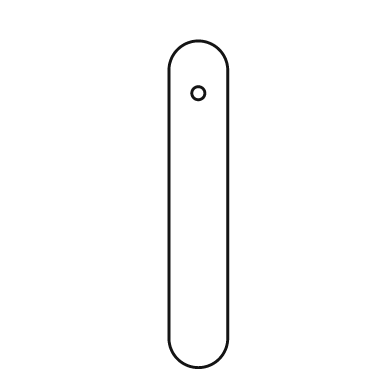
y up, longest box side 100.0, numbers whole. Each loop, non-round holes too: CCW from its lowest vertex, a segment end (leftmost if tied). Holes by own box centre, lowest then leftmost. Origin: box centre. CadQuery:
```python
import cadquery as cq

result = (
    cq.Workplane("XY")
    .moveTo(-9.0, -41.0)
    .threePointArc((0.0, -50.0), (9.0, -41.0))
    .lineTo(9.0, 41.0)
    .threePointArc((0.0, 50.0), (-9.0, 41.0))
    .close()
    .moveTo(0.0, 34.0)
    .circle(2.0)
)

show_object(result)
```